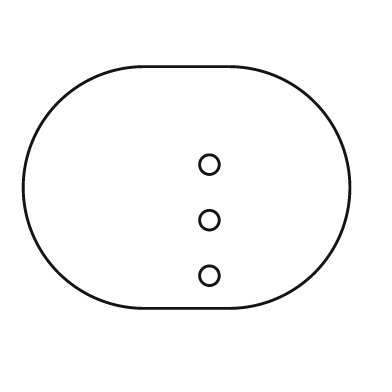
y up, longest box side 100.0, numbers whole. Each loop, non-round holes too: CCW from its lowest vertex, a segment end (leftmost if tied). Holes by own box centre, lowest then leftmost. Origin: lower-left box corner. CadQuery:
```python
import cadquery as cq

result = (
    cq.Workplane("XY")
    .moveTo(37.0, 0.0)
    .lineTo(63.0, 0.0)
    .threePointArc((100.0, 37.0), (63.0, 74.0))
    .lineTo(37.0, 74.0)
    .threePointArc((0.0, 37.0), (37.0, 0.0))
    .close()
    .moveTo(57.0, 10.0)
    .circle(3.0)
    .moveTo(57.0, 27.0)
    .circle(3.0)
    .moveTo(57.0, 44.0)
    .circle(3.0)
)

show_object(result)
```